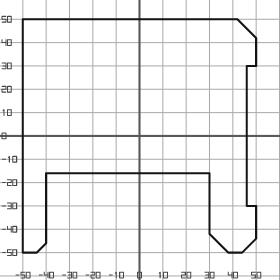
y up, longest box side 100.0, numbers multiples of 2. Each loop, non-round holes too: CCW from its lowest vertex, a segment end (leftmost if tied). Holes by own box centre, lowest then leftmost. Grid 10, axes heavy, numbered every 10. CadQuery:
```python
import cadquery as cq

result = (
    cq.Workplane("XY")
    .moveTo(-50.0, -50.0)
    .lineTo(-44.0, -50.0)
    .lineTo(-40.0, -46.0)
    .lineTo(-40.0, -16.0)
    .lineTo(30.0, -16.0)
    .lineTo(30.0, -42.0)
    .lineTo(38.0, -50.0)
    .lineTo(44.0, -50.0)
    .lineTo(50.0, -44.0)
    .lineTo(50.0, -30.0)
    .lineTo(46.0, -30.0)
    .lineTo(46.0, 30.0)
    .lineTo(50.0, 30.0)
    .lineTo(50.0, 42.0)
    .lineTo(42.0, 50.0)
    .lineTo(-50.0, 50.0)
    .close()
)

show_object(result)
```